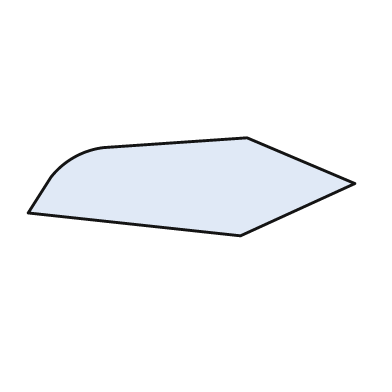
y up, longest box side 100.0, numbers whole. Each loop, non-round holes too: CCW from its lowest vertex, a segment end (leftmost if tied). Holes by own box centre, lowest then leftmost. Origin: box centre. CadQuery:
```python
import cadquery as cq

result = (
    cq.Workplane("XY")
    .moveTo(15.0, -15.0)
    .lineTo(50.0, 1.0)
    .lineTo(17.0, 15.0)
    .lineTo(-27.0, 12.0)
    .threePointArc((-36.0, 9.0), (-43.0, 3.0))
    .lineTo(-50.0, -8.0)
    .close()
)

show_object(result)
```